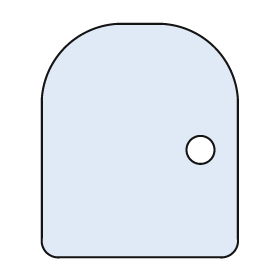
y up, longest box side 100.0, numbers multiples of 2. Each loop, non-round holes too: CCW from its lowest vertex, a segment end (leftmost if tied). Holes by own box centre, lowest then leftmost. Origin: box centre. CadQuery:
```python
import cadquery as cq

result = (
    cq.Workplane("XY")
    .moveTo(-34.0, -50.0)
    .lineTo(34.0, -50.0)
    .threePointArc((40.0, -48.0), (42.0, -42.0))
    .lineTo(42.0, 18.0)
    .threePointArc((32.0, 40.0), (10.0, 50.0))
    .lineTo(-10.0, 50.0)
    .threePointArc((-32.0, 40.0), (-42.0, 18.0))
    .lineTo(-42.0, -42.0)
    .threePointArc((-40.0, -48.0), (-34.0, -50.0))
    .close()
    .moveTo(26.0, -4.0)
    .circle(6.0)
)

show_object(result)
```